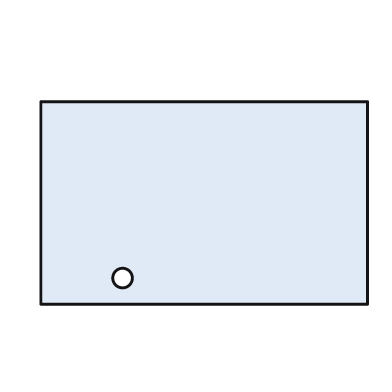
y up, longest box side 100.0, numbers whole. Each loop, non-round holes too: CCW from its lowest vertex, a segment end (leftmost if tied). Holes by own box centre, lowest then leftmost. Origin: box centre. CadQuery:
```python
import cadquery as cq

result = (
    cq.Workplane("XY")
    .moveTo(-50.0, -31.0)
    .lineTo(50.0, -31.0)
    .lineTo(50.0, 31.0)
    .lineTo(-50.0, 31.0)
    .close()
    .moveTo(-25.0, -23.0)
    .circle(3.0)
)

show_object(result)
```